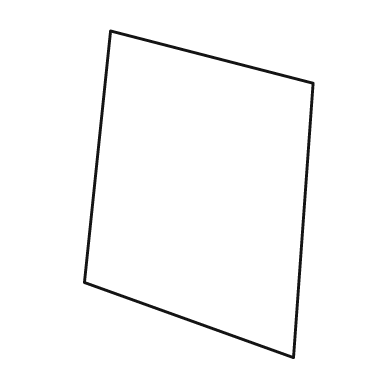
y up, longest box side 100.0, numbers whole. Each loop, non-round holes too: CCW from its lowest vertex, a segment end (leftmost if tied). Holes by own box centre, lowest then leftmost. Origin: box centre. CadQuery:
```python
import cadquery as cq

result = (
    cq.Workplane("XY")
    .moveTo(29.0, -50.0)
    .lineTo(35.0, 34.0)
    .lineTo(-27.0, 50.0)
    .lineTo(-35.0, -27.0)
    .close()
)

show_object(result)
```